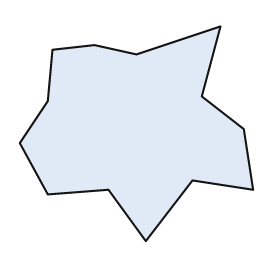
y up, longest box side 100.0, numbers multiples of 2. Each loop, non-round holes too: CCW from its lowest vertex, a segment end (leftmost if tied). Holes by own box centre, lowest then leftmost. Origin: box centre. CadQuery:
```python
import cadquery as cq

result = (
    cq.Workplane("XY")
    .moveTo(4.0, -46.0)
    .lineTo(24.0, -20.0)
    .lineTo(50.0, -24.0)
    .lineTo(46.0, 2.0)
    .lineTo(28.0, 16.0)
    .lineTo(36.0, 46.0)
    .lineTo(0.0, 34.0)
    .lineTo(-18.0, 38.0)
    .lineTo(-36.0, 36.0)
    .lineTo(-38.0, 14.0)
    .lineTo(-50.0, -4.0)
    .lineTo(-38.0, -26.0)
    .lineTo(-12.0, -24.0)
    .close()
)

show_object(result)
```